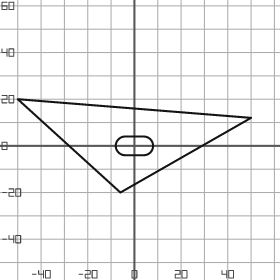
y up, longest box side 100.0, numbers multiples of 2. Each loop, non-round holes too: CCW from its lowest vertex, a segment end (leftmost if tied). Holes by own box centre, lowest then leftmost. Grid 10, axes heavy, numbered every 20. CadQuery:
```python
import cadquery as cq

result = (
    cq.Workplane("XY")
    .moveTo(-6.0, -20.0)
    .lineTo(50.0, 12.0)
    .lineTo(-50.0, 20.0)
    .close()
    .moveTo(-4.0, -4.0)
    .lineTo(4.0, -4.0)
    .threePointArc((8.0, 0.0), (4.0, 4.0))
    .lineTo(-4.0, 4.0)
    .threePointArc((-8.0, 0.0), (-4.0, -4.0))
    .close()
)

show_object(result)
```